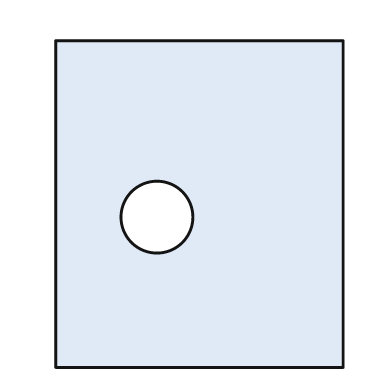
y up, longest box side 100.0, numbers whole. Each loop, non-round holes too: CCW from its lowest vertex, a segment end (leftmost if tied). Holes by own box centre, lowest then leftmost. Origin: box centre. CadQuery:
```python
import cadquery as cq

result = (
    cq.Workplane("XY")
    .moveTo(-44.0, -50.0)
    .lineTo(44.0, -50.0)
    .lineTo(44.0, 50.0)
    .lineTo(-44.0, 50.0)
    .close()
    .moveTo(-13.0, -4.0)
    .circle(11.0)
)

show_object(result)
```